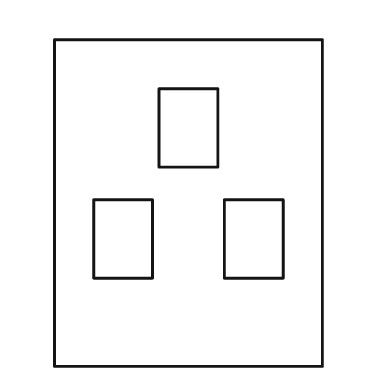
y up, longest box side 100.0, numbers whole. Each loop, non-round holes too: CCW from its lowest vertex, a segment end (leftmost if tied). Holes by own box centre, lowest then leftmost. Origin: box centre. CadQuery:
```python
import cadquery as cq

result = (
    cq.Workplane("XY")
    .moveTo(-41.0, -50.0)
    .lineTo(41.0, -50.0)
    .lineTo(41.0, 50.0)
    .lineTo(-41.0, 50.0)
    .close()
    .moveTo(-29.0, -23.0)
    .lineTo(-11.0, -23.0)
    .lineTo(-11.0, 1.0)
    .lineTo(-29.0, 1.0)
    .close()
    .moveTo(11.0, -23.0)
    .lineTo(29.0, -23.0)
    .lineTo(29.0, 1.0)
    .lineTo(11.0, 1.0)
    .close()
    .moveTo(-9.0, 11.0)
    .lineTo(9.0, 11.0)
    .lineTo(9.0, 35.0)
    .lineTo(-9.0, 35.0)
    .close()
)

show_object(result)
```